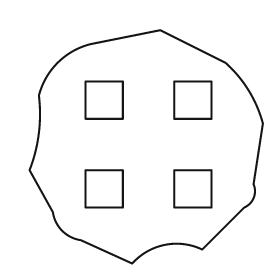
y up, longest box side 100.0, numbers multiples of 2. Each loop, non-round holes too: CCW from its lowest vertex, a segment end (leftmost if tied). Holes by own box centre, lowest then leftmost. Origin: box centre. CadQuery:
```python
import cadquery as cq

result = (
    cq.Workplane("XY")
    .moveTo(-6.0, -50.0)
    .threePointArc((8.0, -42.0), (24.0, -44.0))
    .lineTo(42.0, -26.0)
    .threePointArc((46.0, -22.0), (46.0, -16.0))
    .lineTo(50.0, 10.0)
    .threePointArc((44.0, 24.0), (34.0, 36.0))
    .lineTo(6.0, 50.0)
    .lineTo(-24.0, 44.0)
    .threePointArc((-38.0, 36.0), (-46.0, 22.0))
    .threePointArc((-46.0, 6.0), (-50.0, -10.0))
    .lineTo(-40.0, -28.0)
    .threePointArc((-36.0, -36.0), (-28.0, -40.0))
    .close()
    .moveTo(-26.0, -26.0)
    .lineTo(-10.0, -26.0)
    .lineTo(-10.0, -10.0)
    .lineTo(-26.0, -10.0)
    .close()
    .moveTo(12.0, -26.0)
    .lineTo(28.0, -26.0)
    .lineTo(28.0, -10.0)
    .lineTo(12.0, -10.0)
    .close()
    .moveTo(-26.0, 12.0)
    .lineTo(-10.0, 12.0)
    .lineTo(-10.0, 28.0)
    .lineTo(-26.0, 28.0)
    .close()
    .moveTo(12.0, 12.0)
    .lineTo(28.0, 12.0)
    .lineTo(28.0, 28.0)
    .lineTo(12.0, 28.0)
    .close()
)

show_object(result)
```